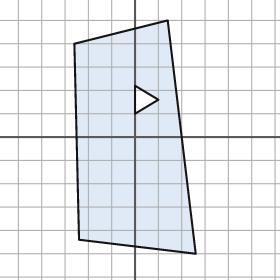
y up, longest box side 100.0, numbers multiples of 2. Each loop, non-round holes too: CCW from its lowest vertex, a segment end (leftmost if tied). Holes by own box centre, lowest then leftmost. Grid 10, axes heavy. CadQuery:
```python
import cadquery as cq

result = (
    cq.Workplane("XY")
    .moveTo(26.0, -50.0)
    .lineTo(14.0, 50.0)
    .lineTo(-26.0, 40.0)
    .lineTo(-24.0, -44.0)
    .close()
    .moveTo(0.0, 10.0)
    .lineTo(10.0, 16.0)
    .lineTo(0.0, 22.0)
    .close()
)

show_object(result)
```